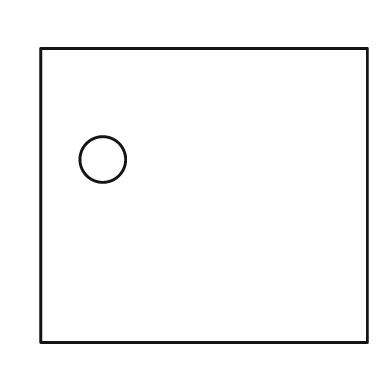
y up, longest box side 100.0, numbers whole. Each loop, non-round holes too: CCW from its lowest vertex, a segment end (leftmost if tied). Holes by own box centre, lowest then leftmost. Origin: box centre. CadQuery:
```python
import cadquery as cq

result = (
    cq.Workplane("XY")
    .moveTo(-50.0, -45.0)
    .lineTo(50.0, -45.0)
    .lineTo(50.0, 45.0)
    .lineTo(-50.0, 45.0)
    .close()
    .moveTo(-31.0, 11.0)
    .circle(7.0)
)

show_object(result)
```